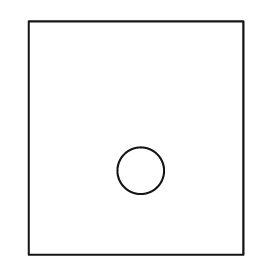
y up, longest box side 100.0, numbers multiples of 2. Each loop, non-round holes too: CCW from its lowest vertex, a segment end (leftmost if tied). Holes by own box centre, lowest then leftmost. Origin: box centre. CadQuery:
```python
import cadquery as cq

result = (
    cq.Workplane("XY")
    .moveTo(-46.0, -50.0)
    .lineTo(46.0, -50.0)
    .lineTo(46.0, 50.0)
    .lineTo(-46.0, 50.0)
    .close()
    .moveTo(2.0, -14.0)
    .circle(10.0)
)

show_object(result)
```